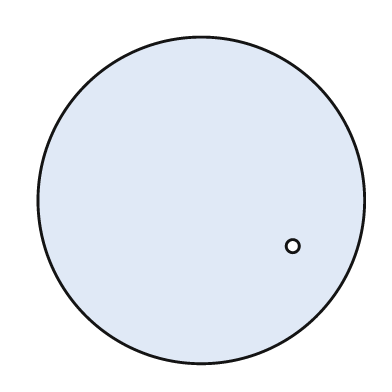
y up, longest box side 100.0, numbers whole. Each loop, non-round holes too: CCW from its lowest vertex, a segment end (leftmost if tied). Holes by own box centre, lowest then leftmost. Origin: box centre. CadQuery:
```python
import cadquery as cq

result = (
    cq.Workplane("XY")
    .moveTo(0.0, 0.0)
    .circle(50.0)
    .moveTo(28.0, -14.0)
    .circle(2.0)
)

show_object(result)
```